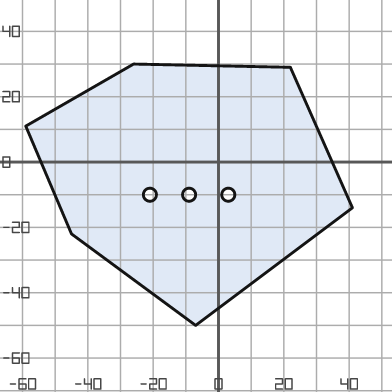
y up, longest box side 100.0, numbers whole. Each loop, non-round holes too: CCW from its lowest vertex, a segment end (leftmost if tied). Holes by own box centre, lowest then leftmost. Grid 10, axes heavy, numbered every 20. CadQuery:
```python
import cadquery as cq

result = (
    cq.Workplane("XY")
    .moveTo(-7.0, -50.0)
    .lineTo(41.0, -14.0)
    .lineTo(22.0, 29.0)
    .lineTo(-26.0, 30.0)
    .lineTo(-59.0, 11.0)
    .lineTo(-45.0, -22.0)
    .close()
    .moveTo(-21.0, -10.0)
    .circle(2.0)
    .moveTo(-9.0, -10.0)
    .circle(2.0)
    .moveTo(3.0, -10.0)
    .circle(2.0)
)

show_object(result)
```